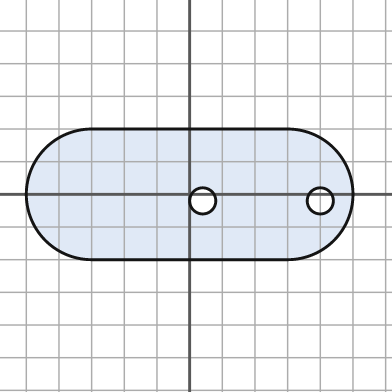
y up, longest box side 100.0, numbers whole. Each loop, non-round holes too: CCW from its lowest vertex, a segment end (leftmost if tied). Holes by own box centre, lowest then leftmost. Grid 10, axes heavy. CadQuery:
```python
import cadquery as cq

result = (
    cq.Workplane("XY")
    .moveTo(-30.0, -20.0)
    .lineTo(30.0, -20.0)
    .threePointArc((50.0, 0.0), (30.0, 20.0))
    .lineTo(-30.0, 20.0)
    .threePointArc((-50.0, 0.0), (-30.0, -20.0))
    .close()
    .moveTo(4.0, -2.0)
    .circle(4.0)
    .moveTo(40.0, -2.0)
    .circle(4.0)
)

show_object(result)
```